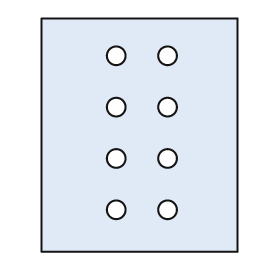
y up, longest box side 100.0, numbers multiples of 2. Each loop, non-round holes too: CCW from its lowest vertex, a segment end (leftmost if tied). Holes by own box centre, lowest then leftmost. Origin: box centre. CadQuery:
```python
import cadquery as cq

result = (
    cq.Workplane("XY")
    .moveTo(-42.0, -50.0)
    .lineTo(42.0, -50.0)
    .lineTo(42.0, 50.0)
    .lineTo(-42.0, 50.0)
    .close()
    .moveTo(-10.0, -32.0)
    .circle(4.0)
    .moveTo(12.0, -32.0)
    .circle(4.0)
    .moveTo(-10.0, -10.0)
    .circle(4.0)
    .moveTo(12.0, -10.0)
    .circle(4.0)
    .moveTo(-10.0, 12.0)
    .circle(4.0)
    .moveTo(12.0, 12.0)
    .circle(4.0)
    .moveTo(-10.0, 34.0)
    .circle(4.0)
    .moveTo(12.0, 34.0)
    .circle(4.0)
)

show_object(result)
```